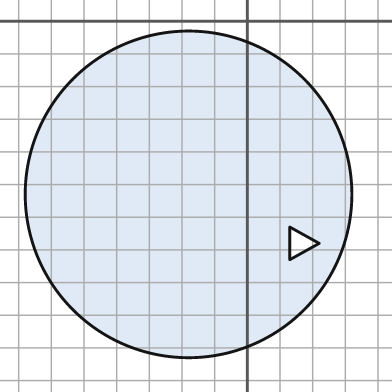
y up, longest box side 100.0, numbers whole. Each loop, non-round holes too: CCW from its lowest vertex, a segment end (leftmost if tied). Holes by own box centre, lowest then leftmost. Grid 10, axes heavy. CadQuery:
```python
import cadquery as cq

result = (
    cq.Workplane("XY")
    .moveTo(-18.0, -53.0)
    .circle(50.0)
    .moveTo(13.0, -73.0)
    .lineTo(22.0, -68.0)
    .lineTo(13.0, -63.0)
    .close()
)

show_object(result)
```